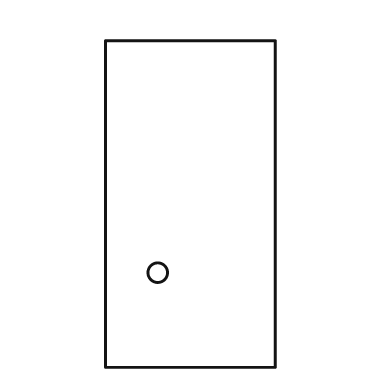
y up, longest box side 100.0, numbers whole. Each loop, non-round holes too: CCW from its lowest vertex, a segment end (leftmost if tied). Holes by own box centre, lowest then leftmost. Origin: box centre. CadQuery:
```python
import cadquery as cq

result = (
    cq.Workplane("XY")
    .moveTo(-26.0, -50.0)
    .lineTo(26.0, -50.0)
    .lineTo(26.0, 50.0)
    .lineTo(-26.0, 50.0)
    .close()
    .moveTo(-10.0, -21.0)
    .circle(3.0)
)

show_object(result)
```